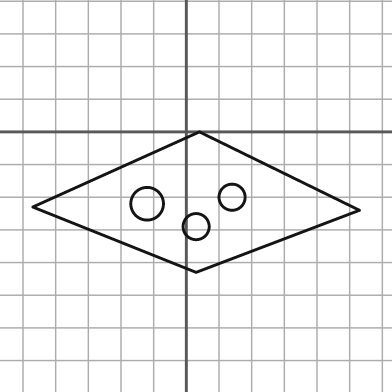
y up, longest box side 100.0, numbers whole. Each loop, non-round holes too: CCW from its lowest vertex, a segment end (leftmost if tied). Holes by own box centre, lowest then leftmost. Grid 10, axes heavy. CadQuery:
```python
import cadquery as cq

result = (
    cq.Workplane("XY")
    .moveTo(3.0, -43.0)
    .lineTo(53.0, -24.0)
    .lineTo(4.0, 0.0)
    .lineTo(-47.0, -23.0)
    .close()
    .moveTo(3.0, -29.0)
    .circle(4.0)
    .moveTo(-12.0, -22.0)
    .circle(5.0)
    .moveTo(14.0, -20.0)
    .circle(4.0)
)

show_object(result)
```